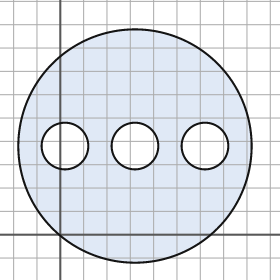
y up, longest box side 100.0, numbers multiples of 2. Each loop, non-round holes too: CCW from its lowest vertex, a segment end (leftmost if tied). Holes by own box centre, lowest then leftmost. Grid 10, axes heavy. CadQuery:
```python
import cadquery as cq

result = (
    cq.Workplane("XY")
    .moveTo(32.0, 38.0)
    .circle(50.0)
    .moveTo(2.0, 38.0)
    .circle(10.0)
    .moveTo(32.0, 38.0)
    .circle(10.0)
    .moveTo(62.0, 38.0)
    .circle(10.0)
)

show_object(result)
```